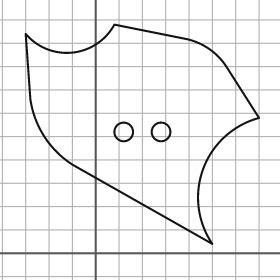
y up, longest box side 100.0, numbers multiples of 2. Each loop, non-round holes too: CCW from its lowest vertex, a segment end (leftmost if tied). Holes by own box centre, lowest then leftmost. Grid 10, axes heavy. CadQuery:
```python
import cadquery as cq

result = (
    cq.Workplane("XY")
    .moveTo(50.0, 4.0)
    .threePointArc((46.0, 36.0), (70.0, 58.0))
    .lineTo(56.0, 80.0)
    .threePointArc((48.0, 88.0), (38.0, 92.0))
    .lineTo(8.0, 98.0)
    .threePointArc((-10.0, 86.0), (-30.0, 94.0))
    .lineTo(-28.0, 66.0)
    .threePointArc((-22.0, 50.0), (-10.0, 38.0))
    .close()
    .moveTo(12.0, 52.0)
    .circle(4.0)
    .moveTo(28.0, 52.0)
    .circle(4.0)
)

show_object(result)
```